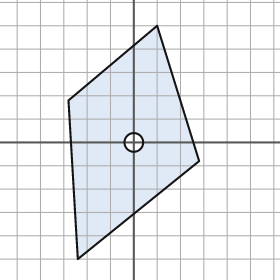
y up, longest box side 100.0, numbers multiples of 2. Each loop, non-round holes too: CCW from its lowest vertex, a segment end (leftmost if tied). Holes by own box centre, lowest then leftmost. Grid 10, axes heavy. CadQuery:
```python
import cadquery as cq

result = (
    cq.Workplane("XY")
    .moveTo(-24.0, -50.0)
    .lineTo(28.0, -8.0)
    .lineTo(10.0, 50.0)
    .lineTo(-28.0, 18.0)
    .close()
    .moveTo(0.0, 0.0)
    .circle(4.0)
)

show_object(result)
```